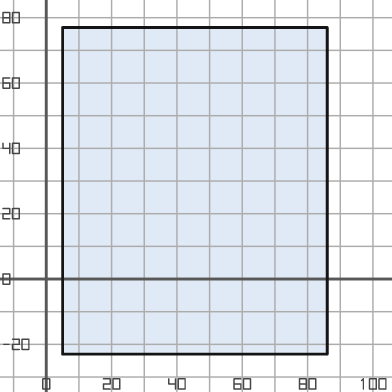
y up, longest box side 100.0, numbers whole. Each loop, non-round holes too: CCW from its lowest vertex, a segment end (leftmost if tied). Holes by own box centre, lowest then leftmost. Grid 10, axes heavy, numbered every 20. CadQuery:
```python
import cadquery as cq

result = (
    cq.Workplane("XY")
    .moveTo(5.0, -23.0)
    .lineTo(86.0, -23.0)
    .lineTo(86.0, 77.0)
    .lineTo(5.0, 77.0)
    .close()
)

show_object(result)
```